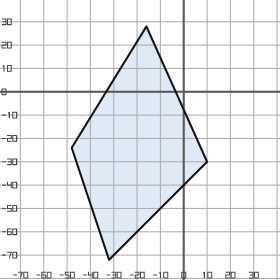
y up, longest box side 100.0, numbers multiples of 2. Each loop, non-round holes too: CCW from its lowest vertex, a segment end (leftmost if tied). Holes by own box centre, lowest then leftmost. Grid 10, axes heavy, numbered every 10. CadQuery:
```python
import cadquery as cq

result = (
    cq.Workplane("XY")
    .moveTo(-32.0, -72.0)
    .lineTo(10.0, -30.0)
    .lineTo(-16.0, 28.0)
    .lineTo(-48.0, -24.0)
    .close()
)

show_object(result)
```